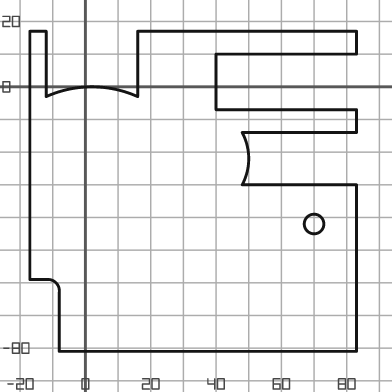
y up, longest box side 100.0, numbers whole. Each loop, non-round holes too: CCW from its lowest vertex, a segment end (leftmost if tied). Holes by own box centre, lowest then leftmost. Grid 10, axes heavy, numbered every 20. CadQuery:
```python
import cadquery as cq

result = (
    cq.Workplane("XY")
    .moveTo(-8.0, -81.0)
    .lineTo(83.0, -81.0)
    .lineTo(83.0, -30.0)
    .lineTo(48.0, -30.0)
    .threePointArc((50.0, -22.0), (48.0, -14.0))
    .lineTo(83.0, -14.0)
    .lineTo(83.0, -7.0)
    .lineTo(40.0, -7.0)
    .lineTo(40.0, 10.0)
    .lineTo(83.0, 10.0)
    .lineTo(83.0, 17.0)
    .lineTo(16.0, 17.0)
    .lineTo(16.0, -3.0)
    .threePointArc((2.0, 0.0), (-12.0, -3.0))
    .lineTo(-12.0, 17.0)
    .lineTo(-17.0, 17.0)
    .lineTo(-17.0, -59.0)
    .lineTo(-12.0, -59.0)
    .threePointArc((-9.0, -60.0), (-8.0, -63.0))
    .close()
    .moveTo(70.0, -42.0)
    .circle(3.0)
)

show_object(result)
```